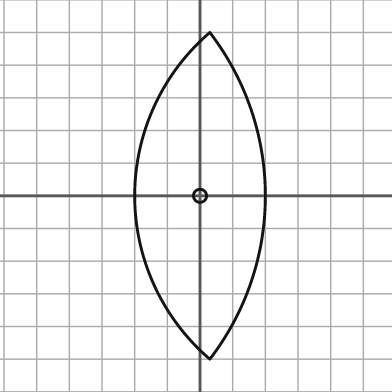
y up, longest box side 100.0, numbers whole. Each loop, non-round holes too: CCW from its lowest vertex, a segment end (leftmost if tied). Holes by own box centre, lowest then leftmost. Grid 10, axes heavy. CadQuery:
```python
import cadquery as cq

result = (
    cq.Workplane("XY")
    .moveTo(3.0, -50.0)
    .threePointArc((20.0, 0.0), (3.0, 50.0))
    .threePointArc((-20.0, 0.0), (3.0, -50.0))
    .close()
    .moveTo(0.0, 0.0)
    .circle(2.0)
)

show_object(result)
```